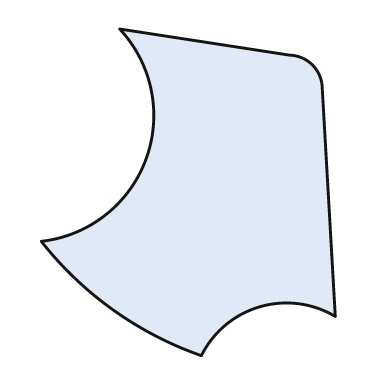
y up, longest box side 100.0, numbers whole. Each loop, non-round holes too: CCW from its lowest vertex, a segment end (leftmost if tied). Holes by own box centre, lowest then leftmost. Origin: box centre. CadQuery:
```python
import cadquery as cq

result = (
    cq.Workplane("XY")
    .moveTo(4.0, -50.0)
    .threePointArc((22.0, -35.0), (45.0, -38.0))
    .lineTo(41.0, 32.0)
    .threePointArc((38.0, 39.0), (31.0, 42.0))
    .lineTo(-21.0, 50.0)
    .threePointArc((-13.0, 10.0), (-45.0, -15.0))
    .threePointArc((-23.0, -36.0), (4.0, -50.0))
    .close()
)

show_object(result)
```